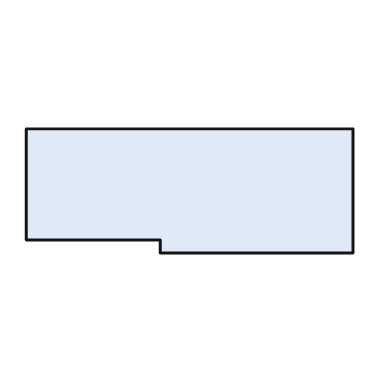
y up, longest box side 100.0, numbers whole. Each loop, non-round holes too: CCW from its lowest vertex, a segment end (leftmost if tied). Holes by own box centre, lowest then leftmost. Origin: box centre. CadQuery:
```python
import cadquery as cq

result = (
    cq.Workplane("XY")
    .moveTo(-9.0, -19.0)
    .lineTo(50.0, -19.0)
    .lineTo(50.0, 19.0)
    .lineTo(-50.0, 19.0)
    .lineTo(-50.0, -15.0)
    .lineTo(-9.0, -15.0)
    .close()
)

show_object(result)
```